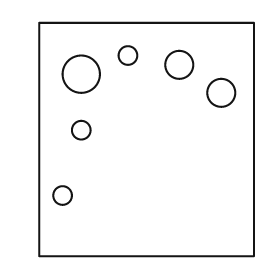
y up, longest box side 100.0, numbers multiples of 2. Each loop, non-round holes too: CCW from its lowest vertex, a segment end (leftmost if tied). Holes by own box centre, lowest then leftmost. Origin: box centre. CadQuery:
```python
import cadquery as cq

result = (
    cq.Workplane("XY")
    .moveTo(-46.0, -50.0)
    .lineTo(46.0, -50.0)
    .lineTo(46.0, 50.0)
    .lineTo(-46.0, 50.0)
    .close()
    .moveTo(-36.0, -24.0)
    .circle(4.0)
    .moveTo(-28.0, 4.0)
    .circle(4.0)
    .moveTo(32.0, 20.0)
    .circle(6.0)
    .moveTo(-28.0, 28.0)
    .circle(8.0)
    .moveTo(14.0, 32.0)
    .circle(6.0)
    .moveTo(-8.0, 36.0)
    .circle(4.0)
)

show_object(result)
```